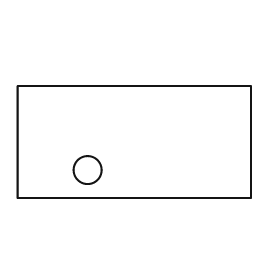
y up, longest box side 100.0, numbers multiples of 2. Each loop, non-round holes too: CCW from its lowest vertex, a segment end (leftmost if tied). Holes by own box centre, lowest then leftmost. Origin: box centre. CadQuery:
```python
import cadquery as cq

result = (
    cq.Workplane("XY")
    .moveTo(-50.0, -24.0)
    .lineTo(50.0, -24.0)
    .lineTo(50.0, 24.0)
    .lineTo(-50.0, 24.0)
    .close()
    .moveTo(-20.0, -12.0)
    .circle(6.0)
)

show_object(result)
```